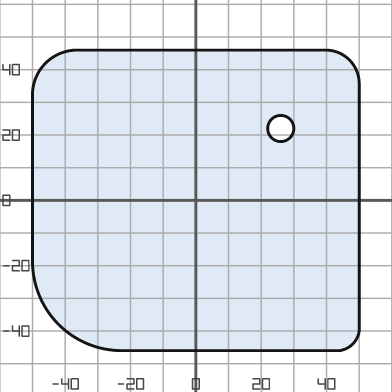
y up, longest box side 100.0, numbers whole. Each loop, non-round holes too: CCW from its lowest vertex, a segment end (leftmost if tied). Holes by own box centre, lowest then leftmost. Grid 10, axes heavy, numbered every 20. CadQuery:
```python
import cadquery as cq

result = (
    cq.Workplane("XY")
    .moveTo(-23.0, -46.0)
    .lineTo(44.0, -46.0)
    .threePointArc((48.0, -44.0), (50.0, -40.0))
    .lineTo(50.0, 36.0)
    .threePointArc((47.0, 43.0), (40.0, 46.0))
    .lineTo(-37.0, 46.0)
    .threePointArc((-46.0, 42.0), (-50.0, 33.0))
    .lineTo(-50.0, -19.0)
    .threePointArc((-42.0, -38.0), (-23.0, -46.0))
    .close()
    .moveTo(26.0, 22.0)
    .circle(4.0)
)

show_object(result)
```